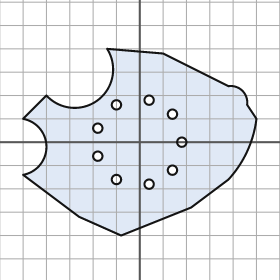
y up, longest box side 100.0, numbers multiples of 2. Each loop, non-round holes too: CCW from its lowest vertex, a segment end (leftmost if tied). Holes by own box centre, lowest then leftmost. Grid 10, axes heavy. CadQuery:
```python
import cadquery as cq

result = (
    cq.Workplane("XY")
    .moveTo(-8.0, -40.0)
    .lineTo(22.0, -28.0)
    .lineTo(38.0, -16.0)
    .threePointArc((46.0, -4.0), (50.0, 10.0))
    .lineTo(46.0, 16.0)
    .threePointArc((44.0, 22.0), (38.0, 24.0))
    .lineTo(10.0, 38.0)
    .lineTo(-14.0, 40.0)
    .threePointArc((-18.0, 18.0), (-40.0, 20.0))
    .lineTo(-50.0, 10.0)
    .threePointArc((-40.0, -2.0), (-50.0, -14.0))
    .lineTo(-26.0, -32.0)
    .close()
    .moveTo(4.0, -18.0)
    .circle(2.0)
    .moveTo(-10.0, -16.0)
    .circle(2.0)
    .moveTo(14.0, -12.0)
    .circle(2.0)
    .moveTo(-18.0, -6.0)
    .circle(2.0)
    .moveTo(18.0, 0.0)
    .circle(2.0)
    .moveTo(-18.0, 6.0)
    .circle(2.0)
    .moveTo(14.0, 12.0)
    .circle(2.0)
    .moveTo(-10.0, 16.0)
    .circle(2.0)
    .moveTo(4.0, 18.0)
    .circle(2.0)
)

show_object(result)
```